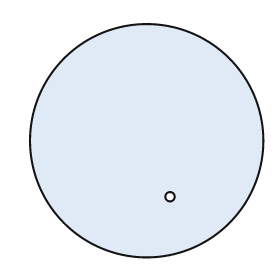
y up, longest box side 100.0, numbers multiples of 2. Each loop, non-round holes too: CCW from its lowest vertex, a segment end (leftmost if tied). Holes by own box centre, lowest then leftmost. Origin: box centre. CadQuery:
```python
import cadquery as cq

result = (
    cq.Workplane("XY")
    .moveTo(0.0, 0.0)
    .circle(50.0)
    .moveTo(10.0, -24.0)
    .circle(2.0)
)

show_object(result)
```